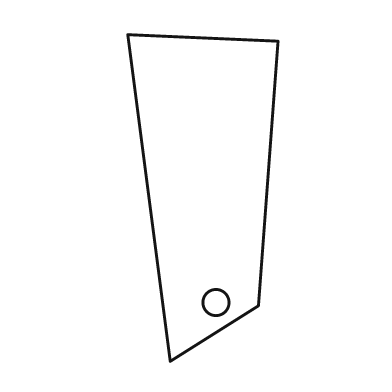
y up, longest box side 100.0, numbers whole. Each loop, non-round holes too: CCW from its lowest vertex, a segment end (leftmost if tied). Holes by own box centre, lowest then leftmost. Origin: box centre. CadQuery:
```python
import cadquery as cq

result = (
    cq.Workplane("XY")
    .moveTo(-10.0, -50.0)
    .lineTo(17.0, -33.0)
    .lineTo(23.0, 48.0)
    .lineTo(-23.0, 50.0)
    .close()
    .moveTo(4.0, -32.0)
    .circle(4.0)
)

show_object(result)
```